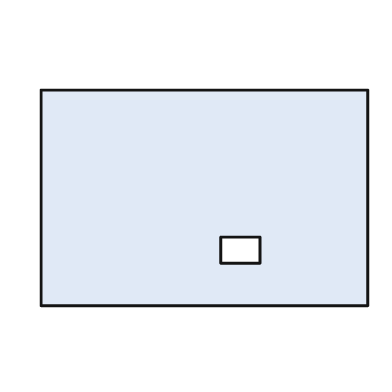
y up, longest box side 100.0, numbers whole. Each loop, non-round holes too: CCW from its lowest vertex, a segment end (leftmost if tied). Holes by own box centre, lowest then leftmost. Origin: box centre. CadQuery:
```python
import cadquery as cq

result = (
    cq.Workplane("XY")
    .moveTo(-50.0, -33.0)
    .lineTo(50.0, -33.0)
    .lineTo(50.0, 33.0)
    .lineTo(-50.0, 33.0)
    .close()
    .moveTo(5.0, -20.0)
    .lineTo(17.0, -20.0)
    .lineTo(17.0, -12.0)
    .lineTo(5.0, -12.0)
    .close()
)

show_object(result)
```